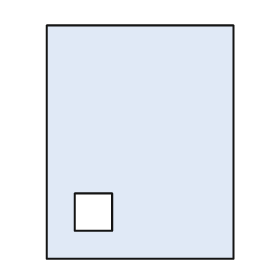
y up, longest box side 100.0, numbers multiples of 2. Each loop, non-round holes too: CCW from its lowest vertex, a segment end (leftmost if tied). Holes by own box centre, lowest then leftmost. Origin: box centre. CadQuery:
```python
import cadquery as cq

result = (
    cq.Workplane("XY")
    .moveTo(-40.0, -50.0)
    .lineTo(40.0, -50.0)
    .lineTo(40.0, 50.0)
    .lineTo(-40.0, 50.0)
    .close()
    .moveTo(-28.0, -38.0)
    .lineTo(-12.0, -38.0)
    .lineTo(-12.0, -22.0)
    .lineTo(-28.0, -22.0)
    .close()
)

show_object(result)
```